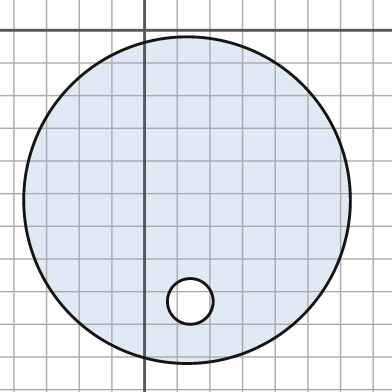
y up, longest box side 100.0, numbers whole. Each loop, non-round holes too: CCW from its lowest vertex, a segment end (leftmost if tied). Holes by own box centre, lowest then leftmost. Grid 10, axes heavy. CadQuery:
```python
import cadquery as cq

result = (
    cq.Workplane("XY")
    .moveTo(13.0, -52.0)
    .circle(50.0)
    .moveTo(14.0, -83.0)
    .circle(7.0)
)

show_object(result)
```